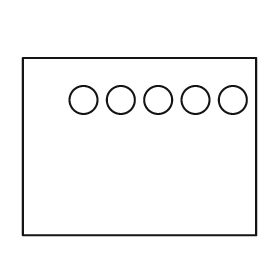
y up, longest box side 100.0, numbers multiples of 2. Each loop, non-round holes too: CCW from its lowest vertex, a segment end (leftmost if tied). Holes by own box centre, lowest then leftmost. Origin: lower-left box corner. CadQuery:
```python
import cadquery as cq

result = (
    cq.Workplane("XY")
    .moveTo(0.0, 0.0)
    .lineTo(100.0, 0.0)
    .lineTo(100.0, 76.0)
    .lineTo(0.0, 76.0)
    .close()
    .moveTo(26.0, 58.0)
    .circle(6.0)
    .moveTo(42.0, 58.0)
    .circle(6.0)
    .moveTo(58.0, 58.0)
    .circle(6.0)
    .moveTo(74.0, 58.0)
    .circle(6.0)
    .moveTo(90.0, 58.0)
    .circle(6.0)
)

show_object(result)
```